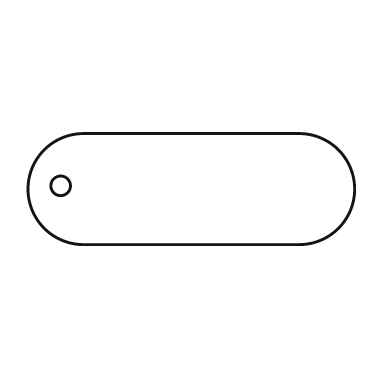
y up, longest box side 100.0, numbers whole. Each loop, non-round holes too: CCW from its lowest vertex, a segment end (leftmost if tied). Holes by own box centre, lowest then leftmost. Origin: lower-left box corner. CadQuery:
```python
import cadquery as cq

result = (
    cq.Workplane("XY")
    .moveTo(17.0, 0.0)
    .lineTo(83.0, 0.0)
    .threePointArc((100.0, 17.0), (83.0, 34.0))
    .lineTo(17.0, 34.0)
    .threePointArc((0.0, 17.0), (17.0, 0.0))
    .close()
    .moveTo(10.0, 18.0)
    .circle(3.0)
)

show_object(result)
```